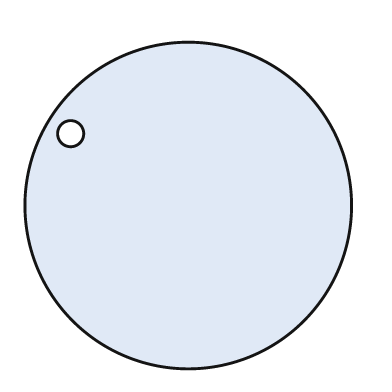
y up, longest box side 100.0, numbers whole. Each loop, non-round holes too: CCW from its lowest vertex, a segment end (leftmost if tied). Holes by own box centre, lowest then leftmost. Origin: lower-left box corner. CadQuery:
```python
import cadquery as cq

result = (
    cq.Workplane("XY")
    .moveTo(50.0, 50.0)
    .circle(50.0)
    .moveTo(14.0, 72.0)
    .circle(4.0)
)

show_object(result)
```